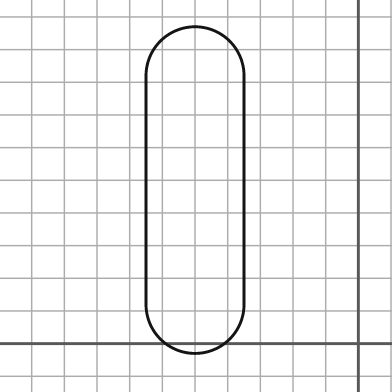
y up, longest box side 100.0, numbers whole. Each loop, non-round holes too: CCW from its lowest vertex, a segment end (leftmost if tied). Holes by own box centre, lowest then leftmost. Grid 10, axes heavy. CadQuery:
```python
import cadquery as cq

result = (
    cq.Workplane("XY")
    .moveTo(-65.0, 12.0)
    .threePointArc((-50.0, -3.0), (-35.0, 12.0))
    .lineTo(-35.0, 82.0)
    .threePointArc((-50.0, 97.0), (-65.0, 82.0))
    .close()
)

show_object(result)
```